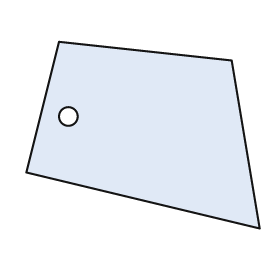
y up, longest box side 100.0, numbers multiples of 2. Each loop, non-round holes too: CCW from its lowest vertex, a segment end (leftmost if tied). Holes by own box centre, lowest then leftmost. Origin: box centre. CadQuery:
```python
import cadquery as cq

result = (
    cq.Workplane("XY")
    .moveTo(50.0, -40.0)
    .lineTo(38.0, 32.0)
    .lineTo(-36.0, 40.0)
    .lineTo(-50.0, -16.0)
    .close()
    .moveTo(-32.0, 8.0)
    .circle(4.0)
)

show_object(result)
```